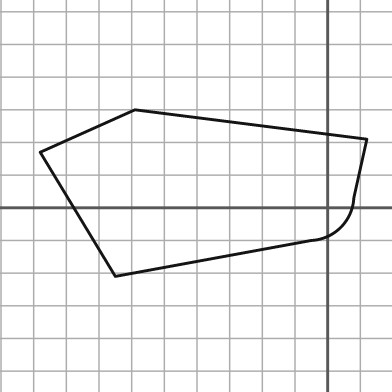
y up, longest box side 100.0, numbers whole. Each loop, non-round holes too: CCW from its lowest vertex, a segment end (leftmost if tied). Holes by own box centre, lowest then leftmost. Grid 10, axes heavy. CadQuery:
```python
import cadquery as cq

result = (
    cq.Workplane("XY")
    .moveTo(-65.0, -21.0)
    .lineTo(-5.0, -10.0)
    .threePointArc((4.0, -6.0), (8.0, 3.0))
    .lineTo(12.0, 21.0)
    .lineTo(-59.0, 30.0)
    .lineTo(-88.0, 17.0)
    .close()
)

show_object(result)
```